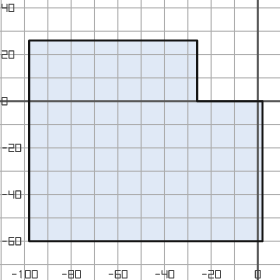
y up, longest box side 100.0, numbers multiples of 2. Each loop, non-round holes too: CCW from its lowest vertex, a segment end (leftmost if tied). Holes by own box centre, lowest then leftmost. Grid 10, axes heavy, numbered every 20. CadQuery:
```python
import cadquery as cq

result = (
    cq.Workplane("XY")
    .moveTo(-98.0, -60.0)
    .lineTo(2.0, -60.0)
    .lineTo(2.0, 0.0)
    .lineTo(-26.0, 0.0)
    .lineTo(-26.0, 26.0)
    .lineTo(-98.0, 26.0)
    .close()
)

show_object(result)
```